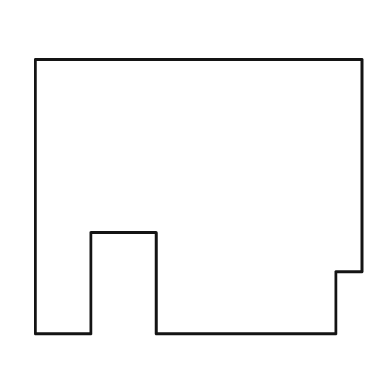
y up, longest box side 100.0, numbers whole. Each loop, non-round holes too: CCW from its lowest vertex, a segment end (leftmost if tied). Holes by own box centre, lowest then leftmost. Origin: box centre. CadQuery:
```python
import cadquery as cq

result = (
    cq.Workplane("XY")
    .moveTo(-50.0, -42.0)
    .lineTo(-33.0, -42.0)
    .lineTo(-33.0, -11.0)
    .lineTo(-13.0, -11.0)
    .lineTo(-13.0, -42.0)
    .lineTo(42.0, -42.0)
    .lineTo(42.0, -23.0)
    .lineTo(50.0, -23.0)
    .lineTo(50.0, 42.0)
    .lineTo(-50.0, 42.0)
    .close()
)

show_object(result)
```